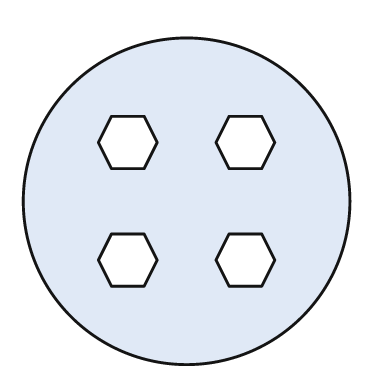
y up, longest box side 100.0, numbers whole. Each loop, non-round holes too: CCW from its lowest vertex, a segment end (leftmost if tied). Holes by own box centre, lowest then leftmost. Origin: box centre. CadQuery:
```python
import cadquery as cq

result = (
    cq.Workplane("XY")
    .moveTo(0.0, 0.0)
    .circle(50.0)
    .moveTo(-23.0, -26.0)
    .lineTo(-13.0, -26.0)
    .lineTo(-9.0, -18.0)
    .lineTo(-13.0, -10.0)
    .lineTo(-23.0, -10.0)
    .lineTo(-27.0, -18.0)
    .close()
    .moveTo(13.0, -26.0)
    .lineTo(23.0, -26.0)
    .lineTo(27.0, -18.0)
    .lineTo(23.0, -10.0)
    .lineTo(13.0, -10.0)
    .lineTo(9.0, -18.0)
    .close()
    .moveTo(-23.0, 10.0)
    .lineTo(-13.0, 10.0)
    .lineTo(-9.0, 18.0)
    .lineTo(-13.0, 26.0)
    .lineTo(-23.0, 26.0)
    .lineTo(-27.0, 18.0)
    .close()
    .moveTo(13.0, 10.0)
    .lineTo(23.0, 10.0)
    .lineTo(27.0, 18.0)
    .lineTo(23.0, 26.0)
    .lineTo(13.0, 26.0)
    .lineTo(9.0, 18.0)
    .close()
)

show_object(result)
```